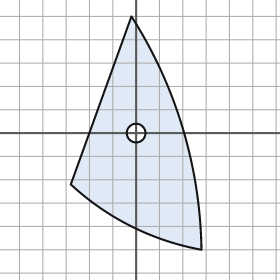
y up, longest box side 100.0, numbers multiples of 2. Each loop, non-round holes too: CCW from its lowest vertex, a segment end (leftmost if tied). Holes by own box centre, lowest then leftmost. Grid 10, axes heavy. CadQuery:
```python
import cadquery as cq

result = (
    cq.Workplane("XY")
    .moveTo(28.0, -50.0)
    .threePointArc((20.0, 2.0), (-2.0, 50.0))
    .lineTo(-28.0, -22.0)
    .threePointArc((-2.0, -40.0), (28.0, -50.0))
    .close()
    .moveTo(0.0, 0.0)
    .circle(4.0)
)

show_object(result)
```